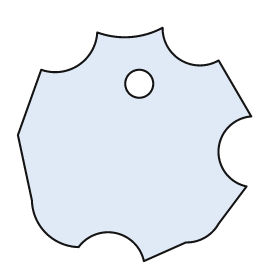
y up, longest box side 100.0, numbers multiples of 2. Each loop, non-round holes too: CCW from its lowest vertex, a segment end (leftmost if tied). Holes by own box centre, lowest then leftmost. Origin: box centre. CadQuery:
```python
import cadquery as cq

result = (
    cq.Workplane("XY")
    .moveTo(4.0, -50.0)
    .lineTo(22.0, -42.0)
    .threePointArc((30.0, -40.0), (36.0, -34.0))
    .lineTo(48.0, -18.0)
    .threePointArc((36.0, -2.0), (50.0, 12.0))
    .lineTo(36.0, 36.0)
    .threePointArc((20.0, 36.0), (12.0, 50.0))
    .threePointArc((-2.0, 46.0), (-16.0, 48.0))
    .threePointArc((-24.0, 34.0), (-40.0, 32.0))
    .lineTo(-50.0, 4.0)
    .lineTo(-44.0, -24.0)
    .threePointArc((-38.0, -38.0), (-24.0, -44.0))
    .threePointArc((-8.0, -38.0), (4.0, -50.0))
    .close()
    .moveTo(2.0, 26.0)
    .circle(6.0)
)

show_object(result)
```